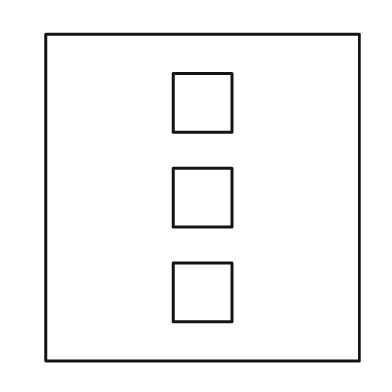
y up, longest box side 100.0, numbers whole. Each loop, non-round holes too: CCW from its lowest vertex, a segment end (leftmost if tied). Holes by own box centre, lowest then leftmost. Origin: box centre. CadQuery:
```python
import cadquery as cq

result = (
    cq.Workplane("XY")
    .moveTo(-48.0, -50.0)
    .lineTo(48.0, -50.0)
    .lineTo(48.0, 50.0)
    .lineTo(-48.0, 50.0)
    .close()
    .moveTo(-9.0, -38.0)
    .lineTo(9.0, -38.0)
    .lineTo(9.0, -20.0)
    .lineTo(-9.0, -20.0)
    .close()
    .moveTo(-9.0, -9.0)
    .lineTo(9.0, -9.0)
    .lineTo(9.0, 9.0)
    .lineTo(-9.0, 9.0)
    .close()
    .moveTo(-9.0, 20.0)
    .lineTo(9.0, 20.0)
    .lineTo(9.0, 38.0)
    .lineTo(-9.0, 38.0)
    .close()
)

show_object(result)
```